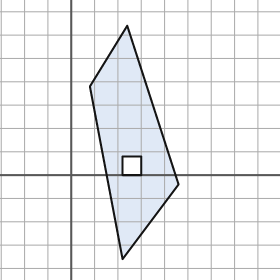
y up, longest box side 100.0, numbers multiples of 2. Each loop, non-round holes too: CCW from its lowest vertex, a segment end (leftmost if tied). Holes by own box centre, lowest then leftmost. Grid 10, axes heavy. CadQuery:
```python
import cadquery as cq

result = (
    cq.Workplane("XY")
    .moveTo(22.0, -36.0)
    .lineTo(46.0, -4.0)
    .lineTo(24.0, 64.0)
    .lineTo(8.0, 38.0)
    .close()
    .moveTo(22.0, 0.0)
    .lineTo(30.0, 0.0)
    .lineTo(30.0, 8.0)
    .lineTo(22.0, 8.0)
    .close()
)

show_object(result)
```